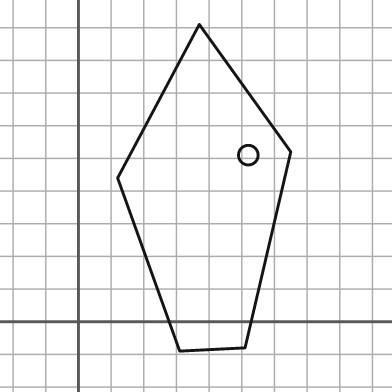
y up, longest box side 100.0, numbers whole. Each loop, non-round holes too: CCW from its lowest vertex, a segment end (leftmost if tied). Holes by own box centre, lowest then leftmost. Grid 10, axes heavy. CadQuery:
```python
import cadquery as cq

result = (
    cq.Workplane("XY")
    .moveTo(31.0, -9.0)
    .lineTo(51.0, -8.0)
    .lineTo(65.0, 52.0)
    .lineTo(37.0, 91.0)
    .lineTo(12.0, 44.0)
    .close()
    .moveTo(52.0, 51.0)
    .circle(3.0)
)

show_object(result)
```